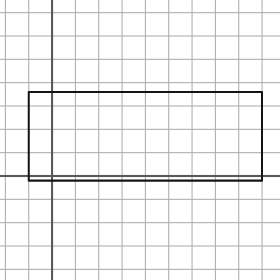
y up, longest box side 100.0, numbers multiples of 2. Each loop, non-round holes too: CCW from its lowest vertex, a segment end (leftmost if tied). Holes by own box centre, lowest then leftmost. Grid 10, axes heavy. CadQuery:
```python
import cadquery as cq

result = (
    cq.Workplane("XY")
    .moveTo(-10.0, -2.0)
    .lineTo(90.0, -2.0)
    .lineTo(90.0, 36.0)
    .lineTo(-10.0, 36.0)
    .close()
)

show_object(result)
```